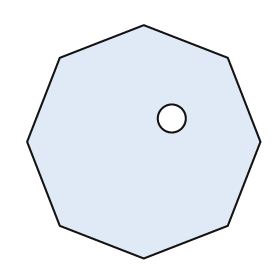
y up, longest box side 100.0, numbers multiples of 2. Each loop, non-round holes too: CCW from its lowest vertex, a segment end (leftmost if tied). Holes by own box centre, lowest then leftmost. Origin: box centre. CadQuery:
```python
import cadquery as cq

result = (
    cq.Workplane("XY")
    .moveTo(0.0, -50.0)
    .lineTo(36.0, -36.0)
    .lineTo(50.0, 0.0)
    .lineTo(36.0, 36.0)
    .lineTo(0.0, 50.0)
    .lineTo(-36.0, 36.0)
    .lineTo(-50.0, 0.0)
    .lineTo(-36.0, -36.0)
    .close()
    .moveTo(12.0, 10.0)
    .circle(6.0)
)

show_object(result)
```